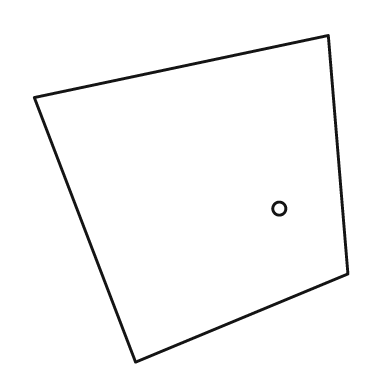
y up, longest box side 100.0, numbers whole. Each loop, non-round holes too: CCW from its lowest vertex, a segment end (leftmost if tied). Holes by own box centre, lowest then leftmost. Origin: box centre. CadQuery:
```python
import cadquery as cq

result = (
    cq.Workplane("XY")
    .moveTo(-17.0, -50.0)
    .lineTo(48.0, -23.0)
    .lineTo(42.0, 50.0)
    .lineTo(-48.0, 31.0)
    .close()
    .moveTo(27.0, -3.0)
    .circle(2.0)
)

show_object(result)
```